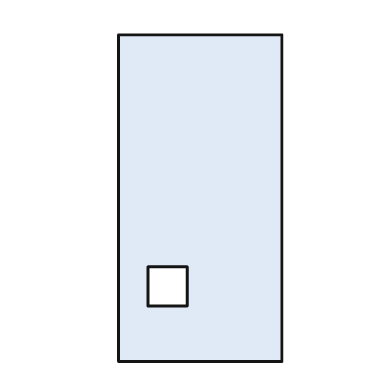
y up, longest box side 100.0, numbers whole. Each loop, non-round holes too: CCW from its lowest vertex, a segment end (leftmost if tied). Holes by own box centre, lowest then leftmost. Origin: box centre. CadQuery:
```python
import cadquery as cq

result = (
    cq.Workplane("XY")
    .moveTo(-25.0, -50.0)
    .lineTo(25.0, -50.0)
    .lineTo(25.0, 50.0)
    .lineTo(-25.0, 50.0)
    .close()
    .moveTo(-16.0, -33.0)
    .lineTo(-4.0, -33.0)
    .lineTo(-4.0, -21.0)
    .lineTo(-16.0, -21.0)
    .close()
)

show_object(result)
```